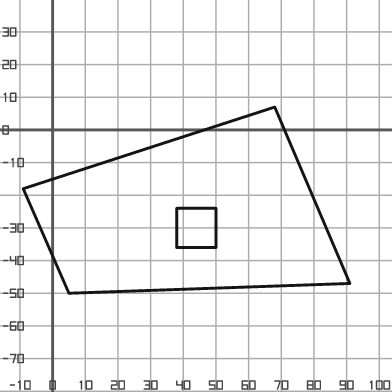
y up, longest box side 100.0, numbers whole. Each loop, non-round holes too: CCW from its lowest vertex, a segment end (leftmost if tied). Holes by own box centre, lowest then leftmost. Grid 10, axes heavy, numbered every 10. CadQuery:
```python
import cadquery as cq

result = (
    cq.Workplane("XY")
    .moveTo(5.0, -50.0)
    .lineTo(91.0, -47.0)
    .lineTo(68.0, 7.0)
    .lineTo(-9.0, -18.0)
    .close()
    .moveTo(38.0, -36.0)
    .lineTo(50.0, -36.0)
    .lineTo(50.0, -24.0)
    .lineTo(38.0, -24.0)
    .close()
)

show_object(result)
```